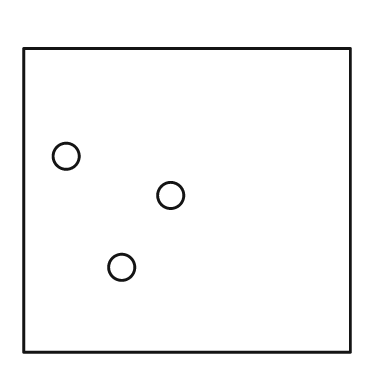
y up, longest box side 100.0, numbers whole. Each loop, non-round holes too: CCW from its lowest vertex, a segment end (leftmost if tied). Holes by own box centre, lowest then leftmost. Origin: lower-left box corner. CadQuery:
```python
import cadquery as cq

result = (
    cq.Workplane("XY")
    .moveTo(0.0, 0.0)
    .lineTo(100.0, 0.0)
    .lineTo(100.0, 93.0)
    .lineTo(0.0, 93.0)
    .close()
    .moveTo(30.0, 26.0)
    .circle(4.0)
    .moveTo(45.0, 48.0)
    .circle(4.0)
    .moveTo(13.0, 60.0)
    .circle(4.0)
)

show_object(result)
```